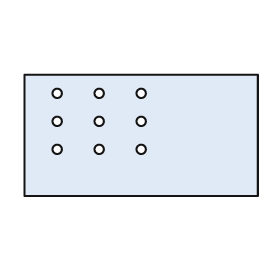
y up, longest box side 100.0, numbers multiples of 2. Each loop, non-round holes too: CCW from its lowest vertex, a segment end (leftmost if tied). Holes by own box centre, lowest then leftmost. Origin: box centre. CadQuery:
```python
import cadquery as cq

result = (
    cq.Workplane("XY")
    .moveTo(-50.0, -26.0)
    .lineTo(50.0, -26.0)
    .lineTo(50.0, 26.0)
    .lineTo(-50.0, 26.0)
    .close()
    .moveTo(-36.0, -6.0)
    .circle(2.0)
    .moveTo(-18.0, -6.0)
    .circle(2.0)
    .moveTo(0.0, -6.0)
    .circle(2.0)
    .moveTo(-36.0, 6.0)
    .circle(2.0)
    .moveTo(-18.0, 6.0)
    .circle(2.0)
    .moveTo(0.0, 6.0)
    .circle(2.0)
    .moveTo(-36.0, 18.0)
    .circle(2.0)
    .moveTo(-18.0, 18.0)
    .circle(2.0)
    .moveTo(0.0, 18.0)
    .circle(2.0)
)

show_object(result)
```